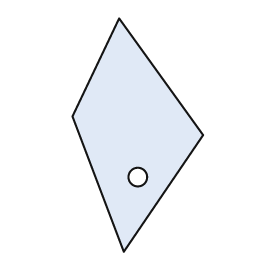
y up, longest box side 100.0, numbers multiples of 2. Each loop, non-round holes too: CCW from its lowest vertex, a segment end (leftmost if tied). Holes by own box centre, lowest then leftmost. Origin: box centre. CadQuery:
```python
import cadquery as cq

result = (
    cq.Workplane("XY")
    .moveTo(-6.0, -50.0)
    .lineTo(28.0, 0.0)
    .lineTo(-8.0, 50.0)
    .lineTo(-28.0, 8.0)
    .close()
    .moveTo(0.0, -18.0)
    .circle(4.0)
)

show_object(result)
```